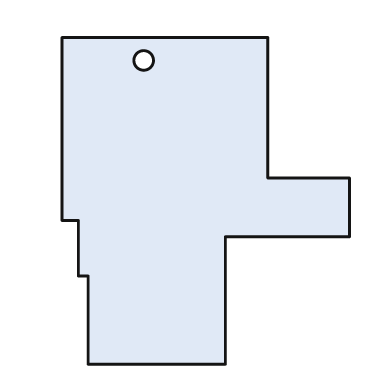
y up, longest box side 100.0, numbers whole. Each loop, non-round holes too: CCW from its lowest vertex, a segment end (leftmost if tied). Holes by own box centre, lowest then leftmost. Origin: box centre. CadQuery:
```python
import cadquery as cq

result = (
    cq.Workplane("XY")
    .moveTo(-36.0, -50.0)
    .lineTo(6.0, -50.0)
    .lineTo(6.0, -11.0)
    .lineTo(44.0, -11.0)
    .lineTo(44.0, 7.0)
    .lineTo(19.0, 7.0)
    .lineTo(19.0, 50.0)
    .lineTo(-44.0, 50.0)
    .lineTo(-44.0, -6.0)
    .lineTo(-39.0, -6.0)
    .lineTo(-39.0, -23.0)
    .lineTo(-36.0, -23.0)
    .close()
    .moveTo(-19.0, 43.0)
    .circle(3.0)
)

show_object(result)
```